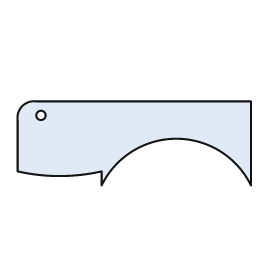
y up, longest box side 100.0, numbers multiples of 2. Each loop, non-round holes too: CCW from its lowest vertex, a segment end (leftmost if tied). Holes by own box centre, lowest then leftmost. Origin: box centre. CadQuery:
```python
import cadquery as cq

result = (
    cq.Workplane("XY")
    .moveTo(-14.0, -18.0)
    .threePointArc((18.0, 2.0), (50.0, -18.0))
    .lineTo(50.0, 18.0)
    .lineTo(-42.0, 18.0)
    .threePointArc((-48.0, 16.0), (-50.0, 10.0))
    .lineTo(-50.0, -12.0)
    .threePointArc((-32.0, -14.0), (-14.0, -12.0))
    .close()
    .moveTo(-40.0, 12.0)
    .circle(2.0)
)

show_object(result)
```